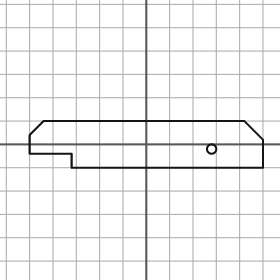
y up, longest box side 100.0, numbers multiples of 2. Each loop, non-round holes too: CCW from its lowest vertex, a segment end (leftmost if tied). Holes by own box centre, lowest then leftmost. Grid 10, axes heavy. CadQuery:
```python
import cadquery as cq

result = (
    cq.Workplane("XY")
    .moveTo(-32.0, -10.0)
    .lineTo(50.0, -10.0)
    .lineTo(50.0, 2.0)
    .lineTo(42.0, 10.0)
    .lineTo(-44.0, 10.0)
    .lineTo(-50.0, 4.0)
    .lineTo(-50.0, -4.0)
    .lineTo(-32.0, -4.0)
    .close()
    .moveTo(28.0, -2.0)
    .circle(2.0)
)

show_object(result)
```